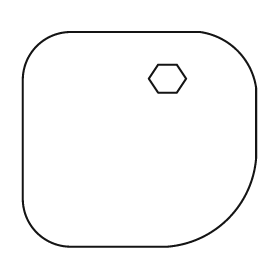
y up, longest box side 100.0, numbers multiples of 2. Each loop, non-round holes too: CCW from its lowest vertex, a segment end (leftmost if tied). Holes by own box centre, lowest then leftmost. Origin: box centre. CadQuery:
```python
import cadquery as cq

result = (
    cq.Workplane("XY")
    .moveTo(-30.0, -46.0)
    .lineTo(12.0, -46.0)
    .threePointArc((38.0, -34.0), (50.0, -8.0))
    .lineTo(50.0, 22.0)
    .threePointArc((42.0, 38.0), (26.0, 46.0))
    .lineTo(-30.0, 46.0)
    .threePointArc((-44.0, 40.0), (-50.0, 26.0))
    .lineTo(-50.0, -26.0)
    .threePointArc((-44.0, -40.0), (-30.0, -46.0))
    .close()
    .moveTo(8.0, 20.0)
    .lineTo(16.0, 20.0)
    .lineTo(20.0, 26.0)
    .lineTo(16.0, 32.0)
    .lineTo(8.0, 32.0)
    .lineTo(4.0, 26.0)
    .close()
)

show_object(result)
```